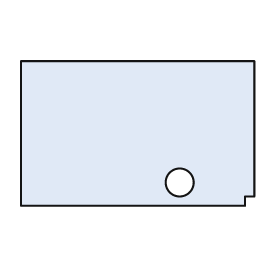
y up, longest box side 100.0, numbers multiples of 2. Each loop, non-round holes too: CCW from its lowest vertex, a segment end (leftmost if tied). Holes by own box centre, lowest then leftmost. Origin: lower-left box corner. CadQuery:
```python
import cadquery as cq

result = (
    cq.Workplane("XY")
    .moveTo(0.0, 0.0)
    .lineTo(96.0, 0.0)
    .lineTo(96.0, 4.0)
    .lineTo(100.0, 4.0)
    .lineTo(100.0, 62.0)
    .lineTo(0.0, 62.0)
    .close()
    .moveTo(68.0, 10.0)
    .circle(6.0)
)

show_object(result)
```